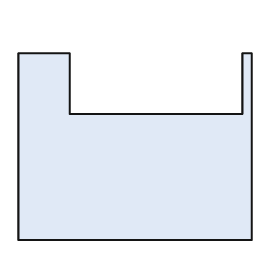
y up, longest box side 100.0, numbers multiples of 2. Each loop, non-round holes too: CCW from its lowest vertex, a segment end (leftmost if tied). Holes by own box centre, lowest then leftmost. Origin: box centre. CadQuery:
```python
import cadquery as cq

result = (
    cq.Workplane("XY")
    .moveTo(-50.0, -40.0)
    .lineTo(50.0, -40.0)
    .lineTo(50.0, 40.0)
    .lineTo(46.0, 40.0)
    .lineTo(46.0, 14.0)
    .lineTo(-28.0, 14.0)
    .lineTo(-28.0, 40.0)
    .lineTo(-50.0, 40.0)
    .close()
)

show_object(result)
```